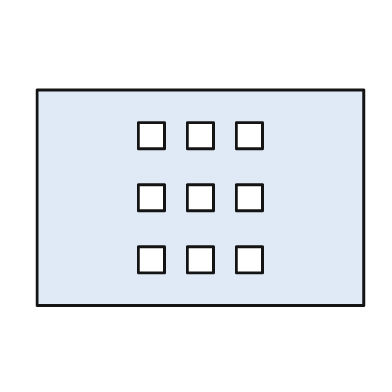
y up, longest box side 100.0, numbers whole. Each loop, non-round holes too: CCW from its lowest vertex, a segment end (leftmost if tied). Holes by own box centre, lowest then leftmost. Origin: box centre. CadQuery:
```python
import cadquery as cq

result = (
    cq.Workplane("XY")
    .moveTo(-50.0, -33.0)
    .lineTo(50.0, -33.0)
    .lineTo(50.0, 33.0)
    .lineTo(-50.0, 33.0)
    .close()
    .moveTo(-19.0, -23.0)
    .lineTo(-11.0, -23.0)
    .lineTo(-11.0, -15.0)
    .lineTo(-19.0, -15.0)
    .close()
    .moveTo(-4.0, -23.0)
    .lineTo(4.0, -23.0)
    .lineTo(4.0, -15.0)
    .lineTo(-4.0, -15.0)
    .close()
    .moveTo(11.0, -23.0)
    .lineTo(19.0, -23.0)
    .lineTo(19.0, -15.0)
    .lineTo(11.0, -15.0)
    .close()
    .moveTo(-19.0, -4.0)
    .lineTo(-11.0, -4.0)
    .lineTo(-11.0, 4.0)
    .lineTo(-19.0, 4.0)
    .close()
    .moveTo(-4.0, -4.0)
    .lineTo(4.0, -4.0)
    .lineTo(4.0, 4.0)
    .lineTo(-4.0, 4.0)
    .close()
    .moveTo(11.0, -4.0)
    .lineTo(19.0, -4.0)
    .lineTo(19.0, 4.0)
    .lineTo(11.0, 4.0)
    .close()
    .moveTo(-19.0, 15.0)
    .lineTo(-11.0, 15.0)
    .lineTo(-11.0, 23.0)
    .lineTo(-19.0, 23.0)
    .close()
    .moveTo(-4.0, 15.0)
    .lineTo(4.0, 15.0)
    .lineTo(4.0, 23.0)
    .lineTo(-4.0, 23.0)
    .close()
    .moveTo(11.0, 15.0)
    .lineTo(19.0, 15.0)
    .lineTo(19.0, 23.0)
    .lineTo(11.0, 23.0)
    .close()
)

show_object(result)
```